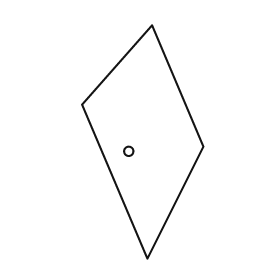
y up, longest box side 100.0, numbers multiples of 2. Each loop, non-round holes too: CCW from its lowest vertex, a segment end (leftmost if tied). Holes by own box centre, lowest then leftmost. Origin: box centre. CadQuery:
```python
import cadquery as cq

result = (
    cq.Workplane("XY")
    .moveTo(2.0, -50.0)
    .lineTo(26.0, -2.0)
    .lineTo(4.0, 50.0)
    .lineTo(-26.0, 16.0)
    .close()
    .moveTo(-6.0, -4.0)
    .circle(2.0)
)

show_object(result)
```